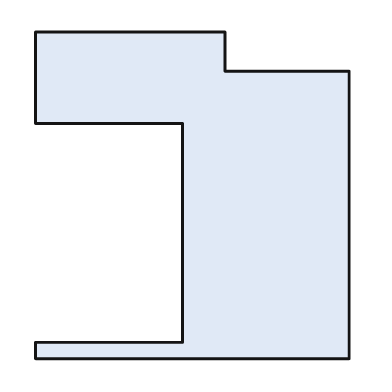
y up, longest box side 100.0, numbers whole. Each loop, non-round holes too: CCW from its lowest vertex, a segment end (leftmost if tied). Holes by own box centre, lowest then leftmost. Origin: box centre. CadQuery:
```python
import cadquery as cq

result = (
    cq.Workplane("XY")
    .moveTo(-48.0, -50.0)
    .lineTo(48.0, -50.0)
    .lineTo(48.0, 38.0)
    .lineTo(10.0, 38.0)
    .lineTo(10.0, 50.0)
    .lineTo(-48.0, 50.0)
    .lineTo(-48.0, 22.0)
    .lineTo(-3.0, 22.0)
    .lineTo(-3.0, -45.0)
    .lineTo(-48.0, -45.0)
    .close()
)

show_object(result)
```